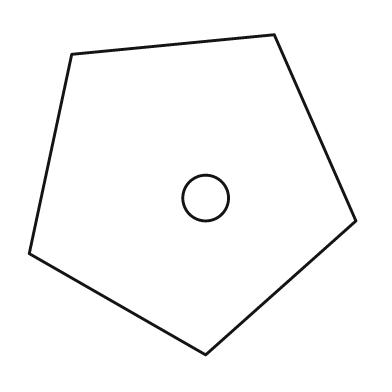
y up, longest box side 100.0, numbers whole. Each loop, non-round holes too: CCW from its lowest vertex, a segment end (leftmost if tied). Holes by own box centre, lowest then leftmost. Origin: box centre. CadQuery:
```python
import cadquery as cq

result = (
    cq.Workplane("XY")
    .moveTo(4.0, -49.0)
    .lineTo(50.0, -8.0)
    .lineTo(25.0, 49.0)
    .lineTo(-37.0, 43.0)
    .lineTo(-50.0, -18.0)
    .close()
    .moveTo(4.0, -1.0)
    .circle(7.0)
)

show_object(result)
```